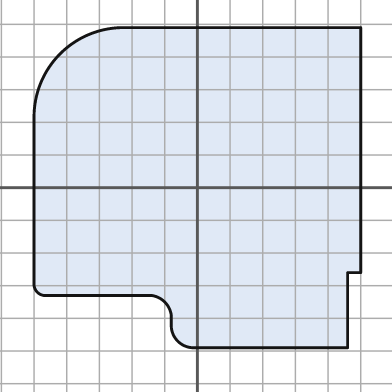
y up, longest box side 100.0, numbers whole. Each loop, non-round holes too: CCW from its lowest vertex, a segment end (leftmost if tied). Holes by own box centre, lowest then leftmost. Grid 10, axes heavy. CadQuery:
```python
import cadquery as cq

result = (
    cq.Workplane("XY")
    .moveTo(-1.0, -49.0)
    .lineTo(46.0, -49.0)
    .lineTo(46.0, -26.0)
    .lineTo(50.0, -26.0)
    .lineTo(50.0, 49.0)
    .lineTo(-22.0, 49.0)
    .threePointArc((-42.0, 41.0), (-50.0, 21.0))
    .lineTo(-50.0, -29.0)
    .threePointArc((-49.0, -32.0), (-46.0, -33.0))
    .lineTo(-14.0, -33.0)
    .threePointArc((-10.0, -35.0), (-8.0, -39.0))
    .lineTo(-8.0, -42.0)
    .threePointArc((-6.0, -47.0), (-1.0, -49.0))
    .close()
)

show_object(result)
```